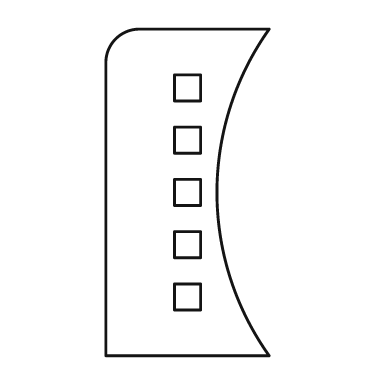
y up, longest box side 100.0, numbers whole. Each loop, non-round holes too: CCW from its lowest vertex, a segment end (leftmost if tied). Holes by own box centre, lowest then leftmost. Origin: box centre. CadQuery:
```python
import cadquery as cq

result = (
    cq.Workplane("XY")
    .moveTo(-25.0, -50.0)
    .lineTo(25.0, -50.0)
    .threePointArc((9.0, 0.0), (25.0, 50.0))
    .lineTo(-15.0, 50.0)
    .threePointArc((-22.0, 47.0), (-25.0, 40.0))
    .close()
    .moveTo(-4.0, -36.0)
    .lineTo(4.0, -36.0)
    .lineTo(4.0, -28.0)
    .lineTo(-4.0, -28.0)
    .close()
    .moveTo(-4.0, -20.0)
    .lineTo(4.0, -20.0)
    .lineTo(4.0, -12.0)
    .lineTo(-4.0, -12.0)
    .close()
    .moveTo(-4.0, -4.0)
    .lineTo(4.0, -4.0)
    .lineTo(4.0, 4.0)
    .lineTo(-4.0, 4.0)
    .close()
    .moveTo(-4.0, 12.0)
    .lineTo(4.0, 12.0)
    .lineTo(4.0, 20.0)
    .lineTo(-4.0, 20.0)
    .close()
    .moveTo(-4.0, 28.0)
    .lineTo(4.0, 28.0)
    .lineTo(4.0, 36.0)
    .lineTo(-4.0, 36.0)
    .close()
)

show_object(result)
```